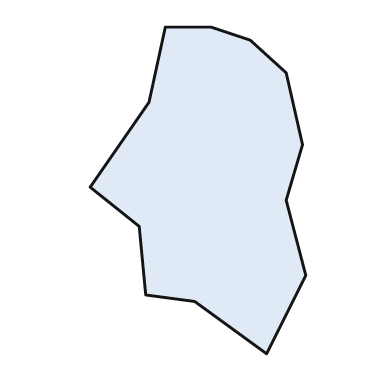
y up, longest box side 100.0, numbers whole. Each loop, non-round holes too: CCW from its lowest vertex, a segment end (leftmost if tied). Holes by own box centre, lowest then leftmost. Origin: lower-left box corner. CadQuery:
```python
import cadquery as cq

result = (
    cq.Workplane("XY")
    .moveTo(54.0, 0.0)
    .lineTo(66.0, 24.0)
    .lineTo(60.0, 47.0)
    .lineTo(65.0, 64.0)
    .lineTo(60.0, 86.0)
    .lineTo(49.0, 96.0)
    .lineTo(37.0, 100.0)
    .lineTo(23.0, 100.0)
    .lineTo(18.0, 77.0)
    .lineTo(0.0, 51.0)
    .lineTo(15.0, 39.0)
    .lineTo(17.0, 18.0)
    .lineTo(32.0, 16.0)
    .close()
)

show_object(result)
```